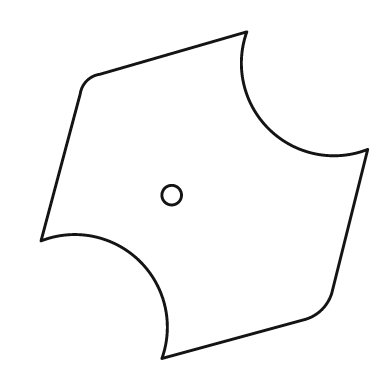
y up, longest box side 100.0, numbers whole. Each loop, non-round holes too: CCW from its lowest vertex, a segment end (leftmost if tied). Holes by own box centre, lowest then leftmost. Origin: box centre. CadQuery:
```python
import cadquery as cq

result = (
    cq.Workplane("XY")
    .moveTo(-13.0, -50.0)
    .lineTo(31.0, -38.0)
    .threePointArc((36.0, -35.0), (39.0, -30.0))
    .lineTo(50.0, 14.0)
    .threePointArc((20.0, 20.0), (13.0, 50.0))
    .lineTo(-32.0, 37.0)
    .threePointArc((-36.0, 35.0), (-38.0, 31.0))
    .lineTo(-50.0, -14.0)
    .threePointArc((-20.0, -20.0), (-13.0, -50.0))
    .close()
    .moveTo(-10.0, 0.0)
    .circle(3.0)
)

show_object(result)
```